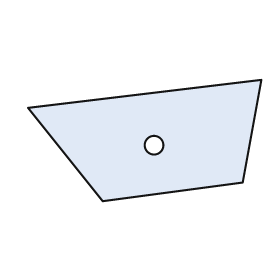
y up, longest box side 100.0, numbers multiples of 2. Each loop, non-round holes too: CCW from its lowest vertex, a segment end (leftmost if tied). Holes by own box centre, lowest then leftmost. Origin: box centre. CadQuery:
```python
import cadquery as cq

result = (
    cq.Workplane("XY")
    .moveTo(-18.0, -26.0)
    .lineTo(42.0, -18.0)
    .lineTo(50.0, 26.0)
    .lineTo(-50.0, 14.0)
    .close()
    .moveTo(4.0, -2.0)
    .circle(4.0)
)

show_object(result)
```